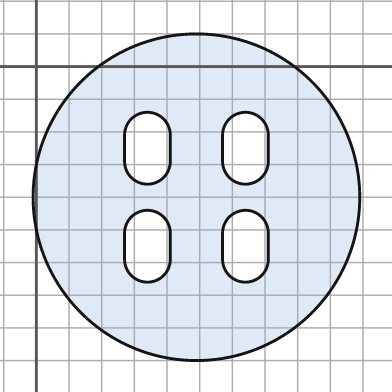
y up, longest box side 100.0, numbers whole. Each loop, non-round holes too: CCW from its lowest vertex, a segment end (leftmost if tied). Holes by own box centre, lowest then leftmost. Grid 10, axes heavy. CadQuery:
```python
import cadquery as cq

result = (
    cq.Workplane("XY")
    .moveTo(49.0, -40.0)
    .circle(50.0)
    .moveTo(27.0, -59.0)
    .threePointArc((34.0, -66.0), (41.0, -59.0))
    .lineTo(41.0, -51.0)
    .threePointArc((34.0, -44.0), (27.0, -51.0))
    .close()
    .moveTo(57.0, -59.0)
    .threePointArc((64.0, -66.0), (71.0, -59.0))
    .lineTo(71.0, -51.0)
    .threePointArc((64.0, -44.0), (57.0, -51.0))
    .close()
    .moveTo(27.0, -29.0)
    .threePointArc((34.0, -36.0), (41.0, -29.0))
    .lineTo(41.0, -21.0)
    .threePointArc((34.0, -14.0), (27.0, -21.0))
    .close()
    .moveTo(57.0, -29.0)
    .threePointArc((64.0, -36.0), (71.0, -29.0))
    .lineTo(71.0, -21.0)
    .threePointArc((64.0, -14.0), (57.0, -21.0))
    .close()
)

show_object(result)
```